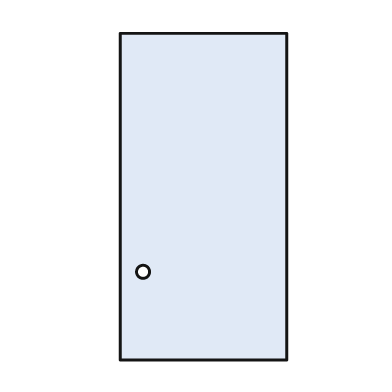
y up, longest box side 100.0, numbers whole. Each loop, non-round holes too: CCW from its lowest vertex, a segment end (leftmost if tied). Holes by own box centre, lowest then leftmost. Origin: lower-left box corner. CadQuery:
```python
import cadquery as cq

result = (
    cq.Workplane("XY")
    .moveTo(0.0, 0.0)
    .lineTo(51.0, 0.0)
    .lineTo(51.0, 100.0)
    .lineTo(0.0, 100.0)
    .close()
    .moveTo(7.0, 27.0)
    .circle(2.0)
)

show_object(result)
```